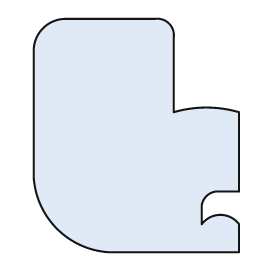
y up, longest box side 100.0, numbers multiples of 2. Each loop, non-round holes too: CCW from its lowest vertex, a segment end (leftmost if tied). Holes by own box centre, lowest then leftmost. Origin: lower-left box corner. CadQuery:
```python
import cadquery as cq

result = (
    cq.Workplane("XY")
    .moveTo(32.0, 0.0)
    .lineTo(88.0, 0.0)
    .lineTo(88.0, 12.0)
    .threePointArc((80.0, 16.0), (72.0, 12.0))
    .lineTo(72.0, 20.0)
    .threePointArc((74.0, 24.0), (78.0, 26.0))
    .lineTo(88.0, 26.0)
    .lineTo(88.0, 60.0)
    .threePointArc((74.0, 62.0), (60.0, 60.0))
    .lineTo(60.0, 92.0)
    .threePointArc((58.0, 98.0), (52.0, 100.0))
    .lineTo(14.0, 100.0)
    .threePointArc((4.0, 96.0), (0.0, 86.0))
    .lineTo(0.0, 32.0)
    .threePointArc((10.0, 10.0), (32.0, 0.0))
    .close()
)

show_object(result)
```